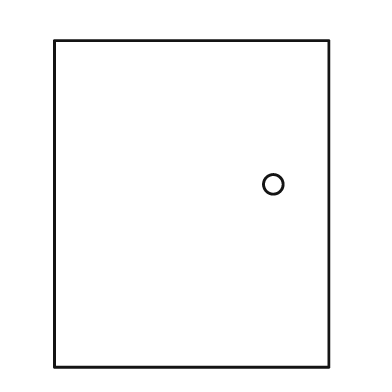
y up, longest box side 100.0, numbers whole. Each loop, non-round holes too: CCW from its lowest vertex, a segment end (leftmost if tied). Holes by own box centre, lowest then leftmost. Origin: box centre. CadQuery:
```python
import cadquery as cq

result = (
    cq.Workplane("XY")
    .moveTo(-42.0, -50.0)
    .lineTo(42.0, -50.0)
    .lineTo(42.0, 50.0)
    .lineTo(-42.0, 50.0)
    .close()
    .moveTo(25.0, 6.0)
    .circle(3.0)
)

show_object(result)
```